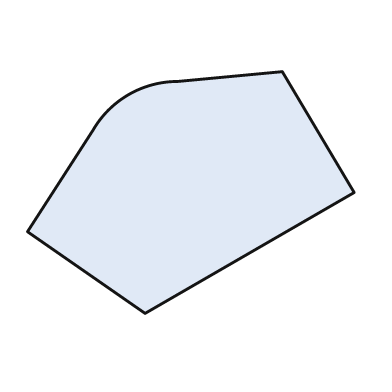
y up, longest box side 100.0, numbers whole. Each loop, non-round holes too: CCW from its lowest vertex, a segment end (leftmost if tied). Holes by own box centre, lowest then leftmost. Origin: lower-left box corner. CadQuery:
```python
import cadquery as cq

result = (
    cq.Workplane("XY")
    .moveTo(36.0, 0.0)
    .lineTo(100.0, 37.0)
    .lineTo(78.0, 74.0)
    .lineTo(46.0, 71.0)
    .threePointArc((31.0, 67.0), (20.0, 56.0))
    .lineTo(0.0, 25.0)
    .close()
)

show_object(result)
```